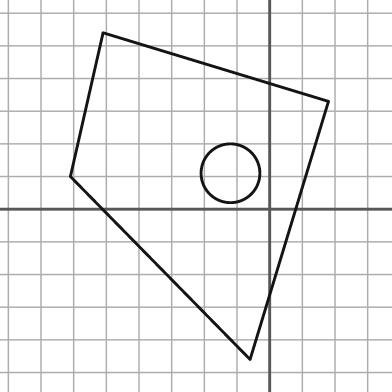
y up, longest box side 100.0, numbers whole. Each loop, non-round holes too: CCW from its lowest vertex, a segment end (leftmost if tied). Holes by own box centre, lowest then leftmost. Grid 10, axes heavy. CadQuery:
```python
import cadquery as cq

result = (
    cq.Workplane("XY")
    .moveTo(-6.0, -46.0)
    .lineTo(18.0, 33.0)
    .lineTo(-51.0, 54.0)
    .lineTo(-61.0, 10.0)
    .close()
    .moveTo(-12.0, 11.0)
    .circle(9.0)
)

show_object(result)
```